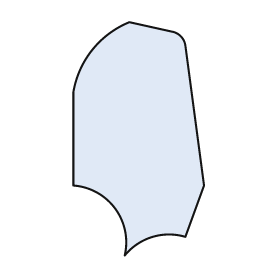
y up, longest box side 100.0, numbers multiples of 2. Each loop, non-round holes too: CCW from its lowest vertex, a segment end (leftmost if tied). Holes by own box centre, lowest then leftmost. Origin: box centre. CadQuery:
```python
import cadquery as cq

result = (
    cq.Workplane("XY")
    .moveTo(-6.0, -50.0)
    .threePointArc((6.0, -42.0), (20.0, -42.0))
    .lineTo(28.0, -20.0)
    .lineTo(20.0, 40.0)
    .threePointArc((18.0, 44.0), (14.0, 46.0))
    .lineTo(-4.0, 50.0)
    .threePointArc((-20.0, 38.0), (-28.0, 20.0))
    .lineTo(-28.0, -20.0)
    .threePointArc((-10.0, -30.0), (-6.0, -50.0))
    .close()
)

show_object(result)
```